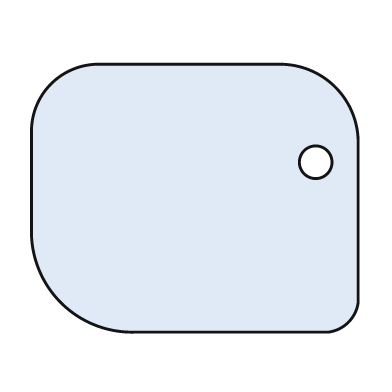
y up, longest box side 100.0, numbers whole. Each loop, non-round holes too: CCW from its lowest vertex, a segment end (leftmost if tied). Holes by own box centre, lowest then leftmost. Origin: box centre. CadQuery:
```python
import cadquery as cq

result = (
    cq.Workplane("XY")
    .moveTo(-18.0, -41.0)
    .lineTo(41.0, -41.0)
    .threePointArc((47.0, -38.0), (50.0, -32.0))
    .lineTo(50.0, 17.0)
    .threePointArc((43.0, 34.0), (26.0, 41.0))
    .lineTo(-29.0, 41.0)
    .threePointArc((-44.0, 35.0), (-50.0, 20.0))
    .lineTo(-50.0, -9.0)
    .threePointArc((-41.0, -32.0), (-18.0, -41.0))
    .close()
    .moveTo(37.0, 11.0)
    .circle(5.0)
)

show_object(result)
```